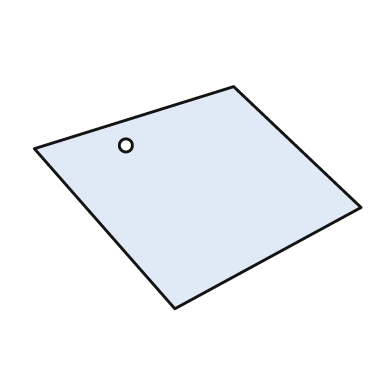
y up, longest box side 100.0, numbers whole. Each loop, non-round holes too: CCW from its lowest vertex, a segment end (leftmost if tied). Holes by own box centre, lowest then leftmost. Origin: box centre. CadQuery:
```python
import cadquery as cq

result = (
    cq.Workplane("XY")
    .moveTo(-7.0, -34.0)
    .lineTo(50.0, -3.0)
    .lineTo(11.0, 34.0)
    .lineTo(-50.0, 15.0)
    .close()
    .moveTo(-22.0, 16.0)
    .circle(2.0)
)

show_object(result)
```